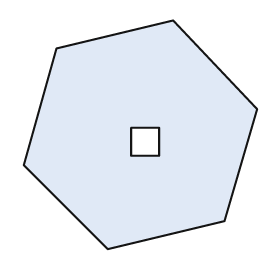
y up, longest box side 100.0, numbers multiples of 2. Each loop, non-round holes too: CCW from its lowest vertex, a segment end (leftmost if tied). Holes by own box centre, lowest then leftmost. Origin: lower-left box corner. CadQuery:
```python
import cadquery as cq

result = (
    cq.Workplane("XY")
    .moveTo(36.0, 0.0)
    .lineTo(86.0, 12.0)
    .lineTo(100.0, 60.0)
    .lineTo(64.0, 98.0)
    .lineTo(14.0, 86.0)
    .lineTo(0.0, 36.0)
    .close()
    .moveTo(46.0, 40.0)
    .lineTo(58.0, 40.0)
    .lineTo(58.0, 52.0)
    .lineTo(46.0, 52.0)
    .close()
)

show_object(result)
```